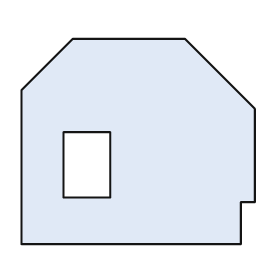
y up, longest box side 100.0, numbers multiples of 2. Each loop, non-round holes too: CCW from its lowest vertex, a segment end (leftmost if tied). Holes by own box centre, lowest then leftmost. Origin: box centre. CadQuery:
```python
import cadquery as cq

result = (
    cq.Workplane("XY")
    .moveTo(-50.0, -44.0)
    .lineTo(44.0, -44.0)
    .lineTo(44.0, -26.0)
    .lineTo(50.0, -26.0)
    .lineTo(50.0, 14.0)
    .lineTo(20.0, 44.0)
    .lineTo(-28.0, 44.0)
    .lineTo(-50.0, 22.0)
    .close()
    .moveTo(-32.0, -24.0)
    .lineTo(-12.0, -24.0)
    .lineTo(-12.0, 4.0)
    .lineTo(-32.0, 4.0)
    .close()
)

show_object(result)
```